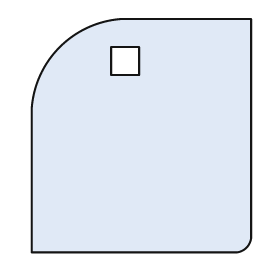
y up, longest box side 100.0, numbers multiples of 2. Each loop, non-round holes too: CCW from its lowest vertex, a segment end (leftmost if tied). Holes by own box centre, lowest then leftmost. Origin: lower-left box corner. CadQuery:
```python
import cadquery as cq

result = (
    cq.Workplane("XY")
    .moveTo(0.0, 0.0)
    .lineTo(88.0, 0.0)
    .threePointArc((92.0, 2.0), (94.0, 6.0))
    .lineTo(94.0, 100.0)
    .lineTo(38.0, 100.0)
    .threePointArc((12.0, 88.0), (0.0, 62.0))
    .close()
    .moveTo(34.0, 76.0)
    .lineTo(46.0, 76.0)
    .lineTo(46.0, 88.0)
    .lineTo(34.0, 88.0)
    .close()
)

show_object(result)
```